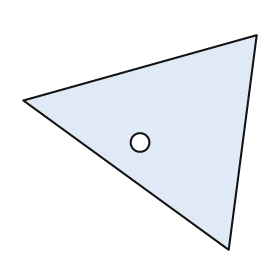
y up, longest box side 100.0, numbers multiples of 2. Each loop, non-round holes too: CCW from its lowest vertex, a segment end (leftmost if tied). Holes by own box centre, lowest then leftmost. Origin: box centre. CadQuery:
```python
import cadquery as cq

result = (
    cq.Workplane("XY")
    .moveTo(38.0, -46.0)
    .lineTo(50.0, 46.0)
    .lineTo(-50.0, 18.0)
    .close()
    .moveTo(0.0, 0.0)
    .circle(4.0)
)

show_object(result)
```